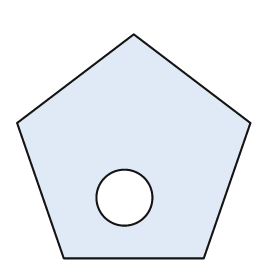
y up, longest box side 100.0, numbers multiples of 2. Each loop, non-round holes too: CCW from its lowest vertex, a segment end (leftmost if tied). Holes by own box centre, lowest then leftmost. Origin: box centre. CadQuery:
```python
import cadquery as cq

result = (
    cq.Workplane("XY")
    .moveTo(-30.0, -48.0)
    .lineTo(30.0, -48.0)
    .lineTo(50.0, 10.0)
    .lineTo(0.0, 48.0)
    .lineTo(-50.0, 10.0)
    .close()
    .moveTo(-4.0, -22.0)
    .circle(12.0)
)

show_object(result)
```